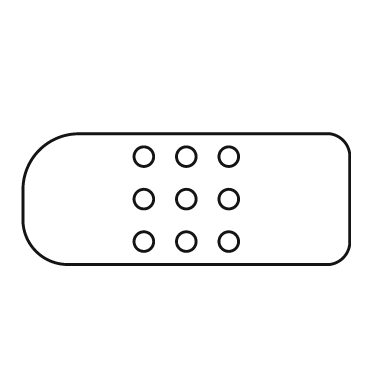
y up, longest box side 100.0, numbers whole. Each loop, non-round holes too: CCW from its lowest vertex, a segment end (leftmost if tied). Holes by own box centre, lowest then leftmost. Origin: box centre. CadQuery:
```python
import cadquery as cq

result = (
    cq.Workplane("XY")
    .moveTo(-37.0, -20.0)
    .lineTo(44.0, -20.0)
    .threePointArc((48.0, -18.0), (50.0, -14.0))
    .lineTo(50.0, 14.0)
    .threePointArc((48.0, 18.0), (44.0, 20.0))
    .lineTo(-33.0, 20.0)
    .threePointArc((-45.0, 15.0), (-50.0, 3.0))
    .lineTo(-50.0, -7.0)
    .threePointArc((-46.0, -16.0), (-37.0, -20.0))
    .close()
    .moveTo(-13.0, -13.0)
    .circle(3.0)
    .moveTo(0.0, -13.0)
    .circle(3.0)
    .moveTo(13.0, -13.0)
    .circle(3.0)
    .moveTo(-13.0, 0.0)
    .circle(3.0)
    .moveTo(0.0, 0.0)
    .circle(3.0)
    .moveTo(13.0, 0.0)
    .circle(3.0)
    .moveTo(-13.0, 13.0)
    .circle(3.0)
    .moveTo(0.0, 13.0)
    .circle(3.0)
    .moveTo(13.0, 13.0)
    .circle(3.0)
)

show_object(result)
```